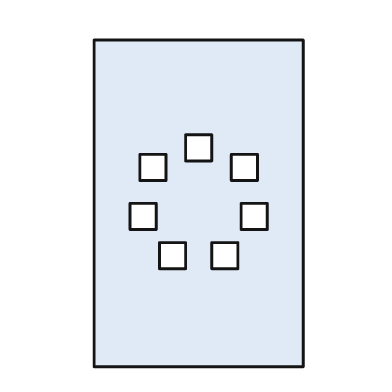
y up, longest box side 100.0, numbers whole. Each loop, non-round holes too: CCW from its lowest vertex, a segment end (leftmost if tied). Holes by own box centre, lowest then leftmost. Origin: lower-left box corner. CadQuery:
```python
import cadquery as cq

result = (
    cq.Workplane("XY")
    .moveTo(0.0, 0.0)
    .lineTo(64.0, 0.0)
    .lineTo(64.0, 100.0)
    .lineTo(0.0, 100.0)
    .close()
    .moveTo(20.0, 30.0)
    .lineTo(28.0, 30.0)
    .lineTo(28.0, 38.0)
    .lineTo(20.0, 38.0)
    .close()
    .moveTo(36.0, 30.0)
    .lineTo(44.0, 30.0)
    .lineTo(44.0, 38.0)
    .lineTo(36.0, 38.0)
    .close()
    .moveTo(11.0, 42.0)
    .lineTo(19.0, 42.0)
    .lineTo(19.0, 50.0)
    .lineTo(11.0, 50.0)
    .close()
    .moveTo(45.0, 42.0)
    .lineTo(53.0, 42.0)
    .lineTo(53.0, 50.0)
    .lineTo(45.0, 50.0)
    .close()
    .moveTo(14.0, 57.0)
    .lineTo(22.0, 57.0)
    .lineTo(22.0, 65.0)
    .lineTo(14.0, 65.0)
    .close()
    .moveTo(42.0, 57.0)
    .lineTo(50.0, 57.0)
    .lineTo(50.0, 65.0)
    .lineTo(42.0, 65.0)
    .close()
    .moveTo(28.0, 63.0)
    .lineTo(36.0, 63.0)
    .lineTo(36.0, 71.0)
    .lineTo(28.0, 71.0)
    .close()
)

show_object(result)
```